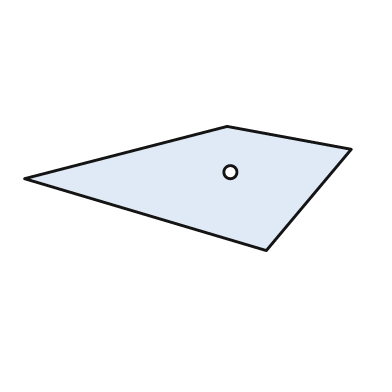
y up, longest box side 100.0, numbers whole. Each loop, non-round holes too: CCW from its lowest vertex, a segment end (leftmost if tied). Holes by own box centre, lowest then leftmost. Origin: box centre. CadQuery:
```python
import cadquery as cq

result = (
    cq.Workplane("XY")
    .moveTo(24.0, -19.0)
    .lineTo(50.0, 12.0)
    .lineTo(12.0, 19.0)
    .lineTo(-50.0, 3.0)
    .close()
    .moveTo(13.0, 5.0)
    .circle(2.0)
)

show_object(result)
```